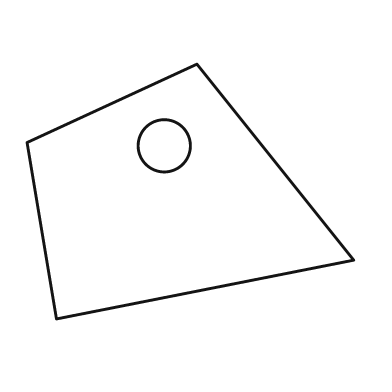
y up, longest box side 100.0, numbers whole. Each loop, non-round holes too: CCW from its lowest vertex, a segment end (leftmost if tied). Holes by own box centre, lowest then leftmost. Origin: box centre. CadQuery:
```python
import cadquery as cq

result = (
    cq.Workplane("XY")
    .moveTo(-41.0, -39.0)
    .lineTo(50.0, -21.0)
    .lineTo(2.0, 39.0)
    .lineTo(-50.0, 15.0)
    .close()
    .moveTo(-8.0, 14.0)
    .circle(8.0)
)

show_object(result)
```